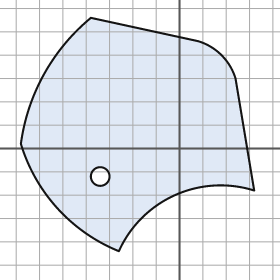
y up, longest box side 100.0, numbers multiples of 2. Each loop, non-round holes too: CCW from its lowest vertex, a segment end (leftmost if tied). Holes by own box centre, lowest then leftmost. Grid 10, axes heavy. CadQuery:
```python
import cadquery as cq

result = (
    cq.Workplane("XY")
    .moveTo(-26.0, -44.0)
    .threePointArc((-2.0, -20.0), (32.0, -18.0))
    .lineTo(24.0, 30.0)
    .threePointArc((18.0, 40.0), (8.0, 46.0))
    .lineTo(-38.0, 56.0)
    .threePointArc((-58.0, 32.0), (-68.0, 2.0))
    .threePointArc((-52.0, -26.0), (-26.0, -44.0))
    .close()
    .moveTo(-34.0, -12.0)
    .circle(4.0)
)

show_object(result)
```